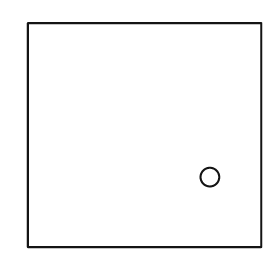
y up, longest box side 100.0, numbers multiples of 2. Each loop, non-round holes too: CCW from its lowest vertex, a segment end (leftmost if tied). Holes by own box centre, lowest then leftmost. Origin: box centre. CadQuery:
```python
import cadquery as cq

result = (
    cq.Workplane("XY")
    .moveTo(-50.0, -48.0)
    .lineTo(50.0, -48.0)
    .lineTo(50.0, 48.0)
    .lineTo(-50.0, 48.0)
    .close()
    .moveTo(28.0, -18.0)
    .circle(4.0)
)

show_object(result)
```